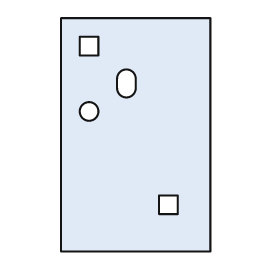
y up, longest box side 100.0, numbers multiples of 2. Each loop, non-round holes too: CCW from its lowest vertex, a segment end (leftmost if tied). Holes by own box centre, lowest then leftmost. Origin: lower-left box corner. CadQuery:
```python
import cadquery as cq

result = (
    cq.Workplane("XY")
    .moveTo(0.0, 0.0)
    .lineTo(64.0, 0.0)
    .lineTo(64.0, 100.0)
    .lineTo(0.0, 100.0)
    .close()
    .moveTo(42.0, 16.0)
    .lineTo(50.0, 16.0)
    .lineTo(50.0, 24.0)
    .lineTo(42.0, 24.0)
    .close()
    .moveTo(12.0, 60.0)
    .circle(4.0)
    .moveTo(24.0, 70.0)
    .threePointArc((28.0, 66.0), (32.0, 70.0))
    .lineTo(32.0, 74.0)
    .threePointArc((28.0, 78.0), (24.0, 74.0))
    .close()
    .moveTo(8.0, 84.0)
    .lineTo(16.0, 84.0)
    .lineTo(16.0, 92.0)
    .lineTo(8.0, 92.0)
    .close()
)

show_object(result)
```